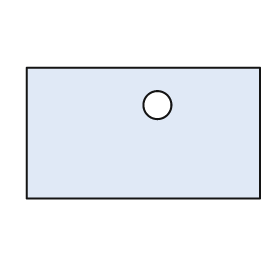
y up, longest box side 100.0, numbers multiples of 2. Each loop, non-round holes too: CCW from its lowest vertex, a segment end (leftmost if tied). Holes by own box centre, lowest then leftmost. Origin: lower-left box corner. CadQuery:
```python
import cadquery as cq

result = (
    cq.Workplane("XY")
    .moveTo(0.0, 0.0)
    .lineTo(100.0, 0.0)
    .lineTo(100.0, 56.0)
    .lineTo(0.0, 56.0)
    .close()
    .moveTo(56.0, 40.0)
    .circle(6.0)
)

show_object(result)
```